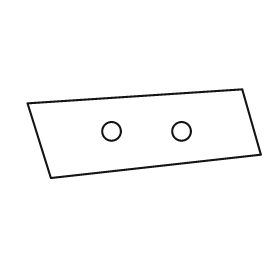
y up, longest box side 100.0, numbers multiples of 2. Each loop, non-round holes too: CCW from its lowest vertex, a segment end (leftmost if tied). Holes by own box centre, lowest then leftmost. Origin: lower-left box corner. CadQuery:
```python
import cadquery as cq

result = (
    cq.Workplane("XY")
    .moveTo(10.0, 0.0)
    .lineTo(100.0, 10.0)
    .lineTo(92.0, 38.0)
    .lineTo(0.0, 32.0)
    .close()
    .moveTo(36.0, 20.0)
    .circle(4.0)
    .moveTo(66.0, 20.0)
    .circle(4.0)
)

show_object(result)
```